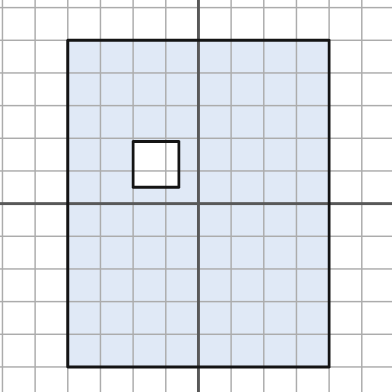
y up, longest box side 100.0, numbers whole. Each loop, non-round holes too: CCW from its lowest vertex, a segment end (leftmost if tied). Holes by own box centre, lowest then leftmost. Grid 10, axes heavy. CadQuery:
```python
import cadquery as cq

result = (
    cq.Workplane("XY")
    .moveTo(-40.0, -50.0)
    .lineTo(40.0, -50.0)
    .lineTo(40.0, 50.0)
    .lineTo(-40.0, 50.0)
    .close()
    .moveTo(-20.0, 5.0)
    .lineTo(-6.0, 5.0)
    .lineTo(-6.0, 19.0)
    .lineTo(-20.0, 19.0)
    .close()
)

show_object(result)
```